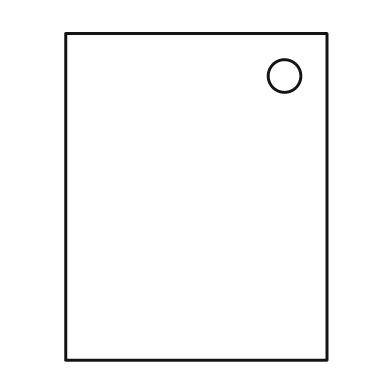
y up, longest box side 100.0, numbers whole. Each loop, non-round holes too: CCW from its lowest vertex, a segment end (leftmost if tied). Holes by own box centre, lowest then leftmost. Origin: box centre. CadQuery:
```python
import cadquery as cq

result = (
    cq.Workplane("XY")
    .moveTo(-40.0, -50.0)
    .lineTo(40.0, -50.0)
    .lineTo(40.0, 50.0)
    .lineTo(-40.0, 50.0)
    .close()
    .moveTo(27.0, 37.0)
    .circle(5.0)
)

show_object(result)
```